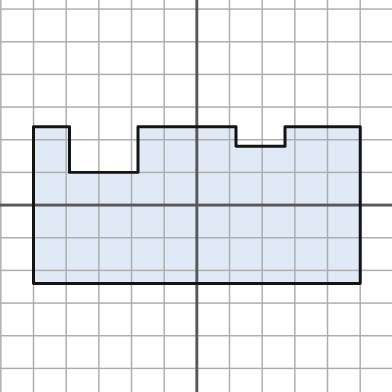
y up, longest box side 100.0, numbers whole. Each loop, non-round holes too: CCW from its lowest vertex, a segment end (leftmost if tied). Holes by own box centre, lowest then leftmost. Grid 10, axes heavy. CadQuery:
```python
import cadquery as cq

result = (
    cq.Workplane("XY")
    .moveTo(-50.0, -24.0)
    .lineTo(50.0, -24.0)
    .lineTo(50.0, 24.0)
    .lineTo(27.0, 24.0)
    .lineTo(27.0, 18.0)
    .lineTo(12.0, 18.0)
    .lineTo(12.0, 24.0)
    .lineTo(-18.0, 24.0)
    .lineTo(-18.0, 10.0)
    .lineTo(-39.0, 10.0)
    .lineTo(-39.0, 24.0)
    .lineTo(-50.0, 24.0)
    .close()
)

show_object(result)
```